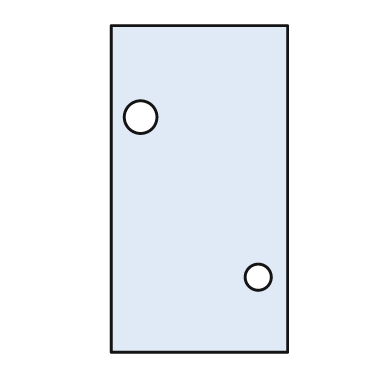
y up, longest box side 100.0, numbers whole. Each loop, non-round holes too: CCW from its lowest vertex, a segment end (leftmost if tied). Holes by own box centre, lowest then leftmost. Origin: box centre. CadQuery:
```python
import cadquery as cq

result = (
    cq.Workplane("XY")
    .moveTo(-27.0, -50.0)
    .lineTo(27.0, -50.0)
    .lineTo(27.0, 50.0)
    .lineTo(-27.0, 50.0)
    .close()
    .moveTo(18.0, -27.0)
    .circle(4.0)
    .moveTo(-18.0, 22.0)
    .circle(5.0)
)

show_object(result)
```